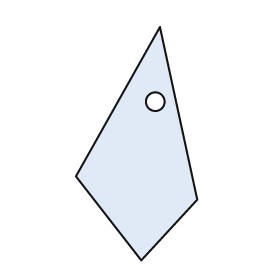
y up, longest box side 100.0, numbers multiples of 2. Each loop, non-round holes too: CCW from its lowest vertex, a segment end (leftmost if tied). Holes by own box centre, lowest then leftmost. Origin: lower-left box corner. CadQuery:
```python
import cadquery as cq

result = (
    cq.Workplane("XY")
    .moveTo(28.0, 0.0)
    .lineTo(52.0, 26.0)
    .lineTo(36.0, 100.0)
    .lineTo(0.0, 36.0)
    .close()
    .moveTo(34.0, 68.0)
    .circle(4.0)
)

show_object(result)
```